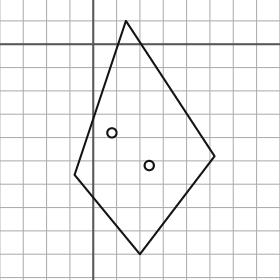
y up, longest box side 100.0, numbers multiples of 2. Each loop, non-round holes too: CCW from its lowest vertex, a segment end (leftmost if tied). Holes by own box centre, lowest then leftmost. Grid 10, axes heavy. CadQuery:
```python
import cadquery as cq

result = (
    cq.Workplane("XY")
    .moveTo(20.0, -90.0)
    .lineTo(52.0, -48.0)
    .lineTo(14.0, 10.0)
    .lineTo(-8.0, -56.0)
    .close()
    .moveTo(24.0, -52.0)
    .circle(2.0)
    .moveTo(8.0, -38.0)
    .circle(2.0)
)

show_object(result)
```